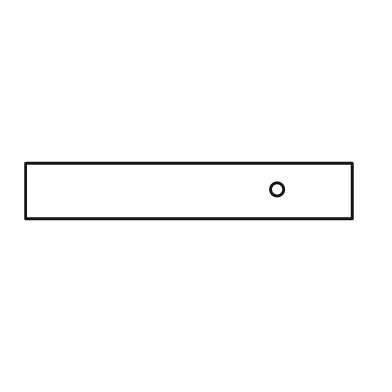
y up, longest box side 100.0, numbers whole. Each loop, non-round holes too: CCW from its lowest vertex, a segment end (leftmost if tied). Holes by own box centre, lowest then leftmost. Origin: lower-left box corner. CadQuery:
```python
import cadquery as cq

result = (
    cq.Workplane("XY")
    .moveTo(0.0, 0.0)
    .lineTo(100.0, 0.0)
    .lineTo(100.0, 17.0)
    .lineTo(0.0, 17.0)
    .close()
    .moveTo(77.0, 9.0)
    .circle(2.0)
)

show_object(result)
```